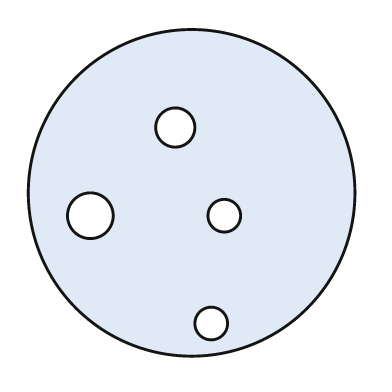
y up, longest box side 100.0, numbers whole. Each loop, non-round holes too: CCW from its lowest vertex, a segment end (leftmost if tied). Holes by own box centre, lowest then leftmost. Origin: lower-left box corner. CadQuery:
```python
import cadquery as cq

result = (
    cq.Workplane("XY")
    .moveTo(50.0, 50.0)
    .circle(50.0)
    .moveTo(56.0, 10.0)
    .circle(5.0)
    .moveTo(19.0, 43.0)
    .circle(7.0)
    .moveTo(60.0, 43.0)
    .circle(5.0)
    .moveTo(45.0, 70.0)
    .circle(6.0)
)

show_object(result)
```